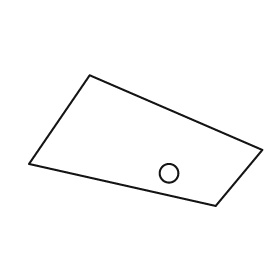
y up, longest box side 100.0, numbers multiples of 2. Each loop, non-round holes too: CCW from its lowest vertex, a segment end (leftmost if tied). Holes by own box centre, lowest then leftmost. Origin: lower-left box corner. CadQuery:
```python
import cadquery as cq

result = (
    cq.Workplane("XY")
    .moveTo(80.0, 0.0)
    .lineTo(100.0, 24.0)
    .lineTo(26.0, 56.0)
    .lineTo(0.0, 18.0)
    .close()
    .moveTo(60.0, 14.0)
    .circle(4.0)
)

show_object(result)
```